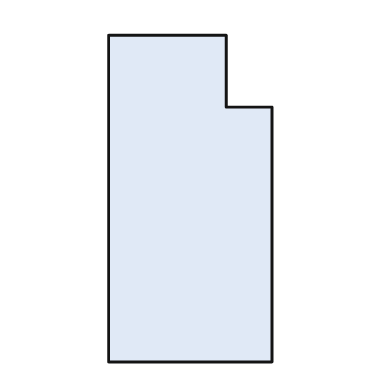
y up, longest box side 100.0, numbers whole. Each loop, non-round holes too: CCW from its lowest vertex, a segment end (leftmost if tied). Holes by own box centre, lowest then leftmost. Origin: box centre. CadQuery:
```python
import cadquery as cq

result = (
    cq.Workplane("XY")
    .moveTo(-25.0, -50.0)
    .lineTo(25.0, -50.0)
    .lineTo(25.0, 28.0)
    .lineTo(11.0, 28.0)
    .lineTo(11.0, 50.0)
    .lineTo(-25.0, 50.0)
    .close()
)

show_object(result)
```